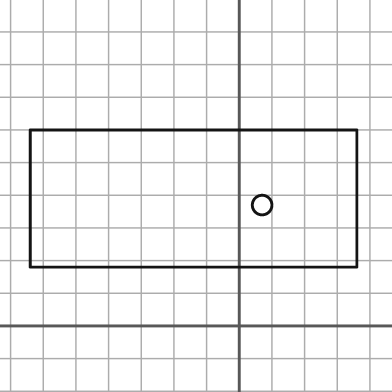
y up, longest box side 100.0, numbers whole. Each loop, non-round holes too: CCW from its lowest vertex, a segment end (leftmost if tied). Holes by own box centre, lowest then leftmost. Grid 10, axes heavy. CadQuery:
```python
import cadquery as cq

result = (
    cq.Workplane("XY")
    .moveTo(-64.0, 18.0)
    .lineTo(36.0, 18.0)
    .lineTo(36.0, 60.0)
    .lineTo(-64.0, 60.0)
    .close()
    .moveTo(7.0, 37.0)
    .circle(3.0)
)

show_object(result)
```